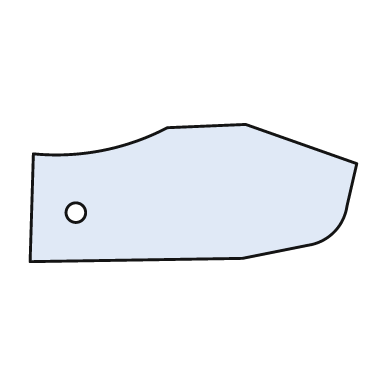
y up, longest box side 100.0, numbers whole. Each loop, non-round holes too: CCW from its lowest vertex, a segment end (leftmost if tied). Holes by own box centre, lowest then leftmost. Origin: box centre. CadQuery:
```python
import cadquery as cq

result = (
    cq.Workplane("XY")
    .moveTo(-50.0, -21.0)
    .lineTo(15.0, -20.0)
    .lineTo(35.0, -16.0)
    .threePointArc((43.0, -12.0), (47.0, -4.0))
    .lineTo(50.0, 9.0)
    .lineTo(16.0, 21.0)
    .lineTo(-8.0, 20.0)
    .threePointArc((-28.0, 13.0), (-49.0, 12.0))
    .close()
    .moveTo(-36.0, -6.0)
    .circle(3.0)
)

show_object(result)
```